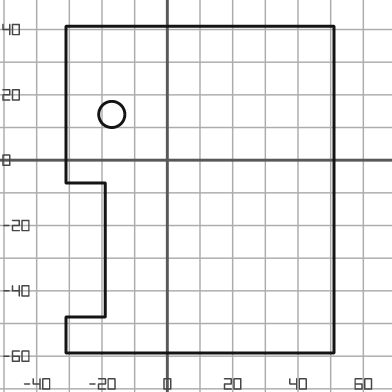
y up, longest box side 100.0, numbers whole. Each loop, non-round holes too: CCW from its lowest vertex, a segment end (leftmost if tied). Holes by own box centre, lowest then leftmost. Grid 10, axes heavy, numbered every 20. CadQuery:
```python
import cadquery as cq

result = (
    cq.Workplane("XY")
    .moveTo(-31.0, -59.0)
    .lineTo(51.0, -59.0)
    .lineTo(51.0, 41.0)
    .lineTo(-31.0, 41.0)
    .lineTo(-31.0, -7.0)
    .lineTo(-19.0, -7.0)
    .lineTo(-19.0, -48.0)
    .lineTo(-31.0, -48.0)
    .close()
    .moveTo(-17.0, 14.0)
    .circle(4.0)
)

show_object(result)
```